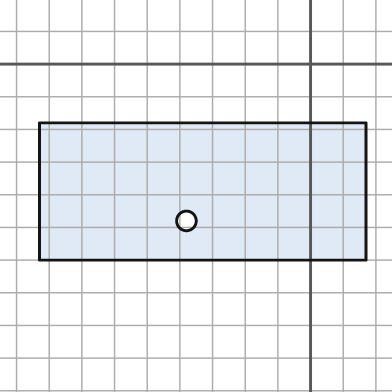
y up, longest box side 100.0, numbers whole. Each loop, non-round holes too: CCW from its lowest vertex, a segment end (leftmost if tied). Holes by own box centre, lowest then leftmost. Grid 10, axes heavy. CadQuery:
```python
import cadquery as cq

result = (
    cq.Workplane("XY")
    .moveTo(-83.0, -60.0)
    .lineTo(17.0, -60.0)
    .lineTo(17.0, -18.0)
    .lineTo(-83.0, -18.0)
    .close()
    .moveTo(-38.0, -48.0)
    .circle(3.0)
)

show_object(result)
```